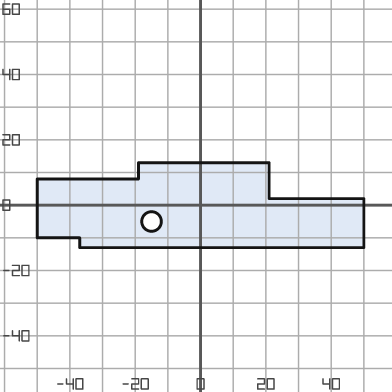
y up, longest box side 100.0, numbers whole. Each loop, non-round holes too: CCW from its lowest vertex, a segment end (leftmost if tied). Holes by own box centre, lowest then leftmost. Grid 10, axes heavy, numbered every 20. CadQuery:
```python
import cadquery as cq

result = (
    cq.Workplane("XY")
    .moveTo(-37.0, -13.0)
    .lineTo(50.0, -13.0)
    .lineTo(50.0, 2.0)
    .lineTo(21.0, 2.0)
    .lineTo(21.0, 13.0)
    .lineTo(-19.0, 13.0)
    .lineTo(-19.0, 8.0)
    .lineTo(-50.0, 8.0)
    .lineTo(-50.0, -10.0)
    .lineTo(-37.0, -10.0)
    .close()
    .moveTo(-15.0, -5.0)
    .circle(3.0)
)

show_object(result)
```